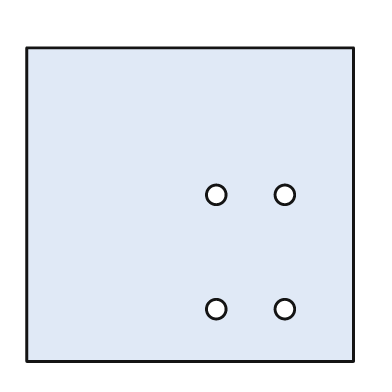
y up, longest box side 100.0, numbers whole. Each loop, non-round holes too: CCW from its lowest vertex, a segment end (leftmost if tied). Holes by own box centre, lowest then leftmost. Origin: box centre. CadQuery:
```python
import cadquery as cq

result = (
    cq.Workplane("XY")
    .moveTo(-50.0, -48.0)
    .lineTo(50.0, -48.0)
    .lineTo(50.0, 48.0)
    .lineTo(-50.0, 48.0)
    .close()
    .moveTo(8.0, -32.0)
    .circle(3.0)
    .moveTo(29.0, -32.0)
    .circle(3.0)
    .moveTo(8.0, 3.0)
    .circle(3.0)
    .moveTo(29.0, 3.0)
    .circle(3.0)
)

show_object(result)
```